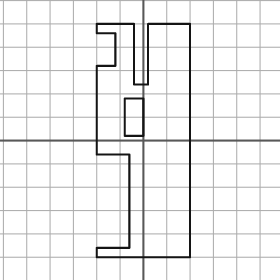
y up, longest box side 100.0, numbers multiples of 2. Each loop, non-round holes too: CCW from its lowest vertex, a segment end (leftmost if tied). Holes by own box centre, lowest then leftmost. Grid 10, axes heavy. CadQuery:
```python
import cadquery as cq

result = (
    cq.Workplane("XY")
    .moveTo(-20.0, -50.0)
    .lineTo(20.0, -50.0)
    .lineTo(20.0, 50.0)
    .lineTo(2.0, 50.0)
    .lineTo(2.0, 24.0)
    .lineTo(-4.0, 24.0)
    .lineTo(-4.0, 50.0)
    .lineTo(-20.0, 50.0)
    .lineTo(-20.0, 46.0)
    .lineTo(-12.0, 46.0)
    .lineTo(-12.0, 32.0)
    .lineTo(-20.0, 32.0)
    .lineTo(-20.0, -6.0)
    .lineTo(-6.0, -6.0)
    .lineTo(-6.0, -46.0)
    .lineTo(-20.0, -46.0)
    .close()
    .moveTo(-8.0, 2.0)
    .lineTo(0.0, 2.0)
    .lineTo(0.0, 18.0)
    .lineTo(-8.0, 18.0)
    .close()
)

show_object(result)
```